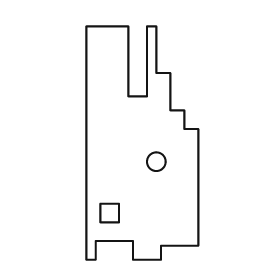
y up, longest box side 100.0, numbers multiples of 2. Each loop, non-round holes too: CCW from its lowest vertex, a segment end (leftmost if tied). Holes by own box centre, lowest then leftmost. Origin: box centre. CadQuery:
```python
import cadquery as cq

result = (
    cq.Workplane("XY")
    .moveTo(-24.0, -50.0)
    .lineTo(-20.0, -50.0)
    .lineTo(-20.0, -42.0)
    .lineTo(-4.0, -42.0)
    .lineTo(-4.0, -50.0)
    .lineTo(8.0, -50.0)
    .lineTo(8.0, -44.0)
    .lineTo(24.0, -44.0)
    .lineTo(24.0, 6.0)
    .lineTo(18.0, 6.0)
    .lineTo(18.0, 14.0)
    .lineTo(12.0, 14.0)
    .lineTo(12.0, 30.0)
    .lineTo(6.0, 30.0)
    .lineTo(6.0, 50.0)
    .lineTo(2.0, 50.0)
    .lineTo(2.0, 20.0)
    .lineTo(-6.0, 20.0)
    .lineTo(-6.0, 50.0)
    .lineTo(-24.0, 50.0)
    .close()
    .moveTo(-18.0, -34.0)
    .lineTo(-10.0, -34.0)
    .lineTo(-10.0, -26.0)
    .lineTo(-18.0, -26.0)
    .close()
    .moveTo(6.0, -8.0)
    .circle(4.0)
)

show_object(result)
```